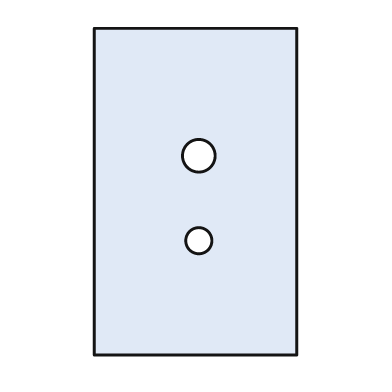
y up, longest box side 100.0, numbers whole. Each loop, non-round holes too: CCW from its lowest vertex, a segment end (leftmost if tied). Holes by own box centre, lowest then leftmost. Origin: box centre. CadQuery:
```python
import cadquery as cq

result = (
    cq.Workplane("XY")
    .moveTo(-31.0, -50.0)
    .lineTo(31.0, -50.0)
    .lineTo(31.0, 50.0)
    .lineTo(-31.0, 50.0)
    .close()
    .moveTo(1.0, -15.0)
    .circle(4.0)
    .moveTo(1.0, 11.0)
    .circle(5.0)
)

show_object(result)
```